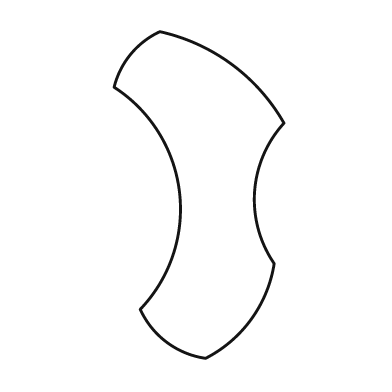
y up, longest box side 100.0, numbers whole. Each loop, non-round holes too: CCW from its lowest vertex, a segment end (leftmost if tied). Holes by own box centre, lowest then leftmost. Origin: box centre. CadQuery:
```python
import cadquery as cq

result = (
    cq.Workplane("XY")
    .moveTo(2.0, -50.0)
    .threePointArc((16.0, -38.0), (23.0, -21.0))
    .threePointArc((17.0, 1.0), (26.0, 22.0))
    .threePointArc((10.0, 40.0), (-12.0, 50.0))
    .threePointArc((-21.0, 43.0), (-26.0, 33.0))
    .threePointArc((-6.0, 1.0), (-18.0, -35.0))
    .threePointArc((-10.0, -45.0), (2.0, -50.0))
    .close()
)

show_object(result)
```